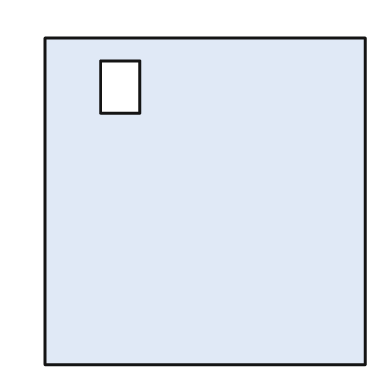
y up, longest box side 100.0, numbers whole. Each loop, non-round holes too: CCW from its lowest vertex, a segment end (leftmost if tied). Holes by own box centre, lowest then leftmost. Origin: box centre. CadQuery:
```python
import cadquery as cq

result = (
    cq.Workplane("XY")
    .moveTo(-49.0, -50.0)
    .lineTo(49.0, -50.0)
    .lineTo(49.0, 50.0)
    .lineTo(-49.0, 50.0)
    .close()
    .moveTo(-32.0, 27.0)
    .lineTo(-20.0, 27.0)
    .lineTo(-20.0, 43.0)
    .lineTo(-32.0, 43.0)
    .close()
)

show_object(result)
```